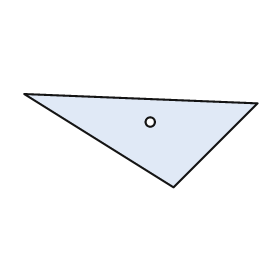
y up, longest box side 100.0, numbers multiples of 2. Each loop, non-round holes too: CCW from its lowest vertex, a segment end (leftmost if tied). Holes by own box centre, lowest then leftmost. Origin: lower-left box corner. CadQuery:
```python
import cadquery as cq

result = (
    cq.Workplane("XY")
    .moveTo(64.0, 0.0)
    .lineTo(100.0, 36.0)
    .lineTo(0.0, 40.0)
    .close()
    .moveTo(54.0, 28.0)
    .circle(2.0)
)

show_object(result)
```